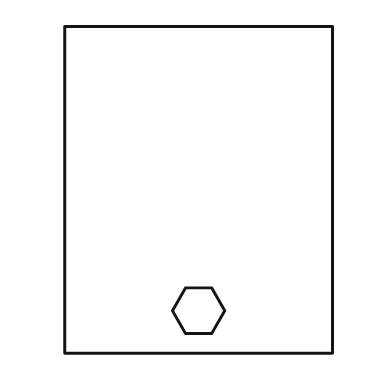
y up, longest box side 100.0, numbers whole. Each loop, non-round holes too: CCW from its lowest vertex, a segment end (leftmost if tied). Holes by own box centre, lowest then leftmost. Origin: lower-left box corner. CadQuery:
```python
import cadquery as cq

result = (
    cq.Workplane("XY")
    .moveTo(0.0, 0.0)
    .lineTo(82.0, 0.0)
    .lineTo(82.0, 100.0)
    .lineTo(0.0, 100.0)
    .close()
    .moveTo(37.0, 6.0)
    .lineTo(45.0, 6.0)
    .lineTo(49.0, 13.0)
    .lineTo(45.0, 20.0)
    .lineTo(37.0, 20.0)
    .lineTo(33.0, 13.0)
    .close()
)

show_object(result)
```